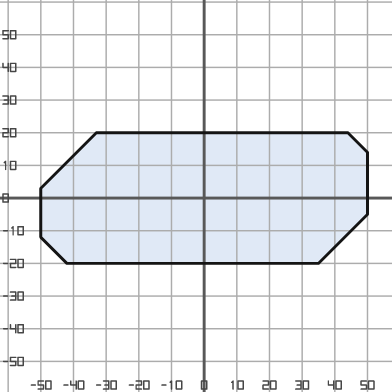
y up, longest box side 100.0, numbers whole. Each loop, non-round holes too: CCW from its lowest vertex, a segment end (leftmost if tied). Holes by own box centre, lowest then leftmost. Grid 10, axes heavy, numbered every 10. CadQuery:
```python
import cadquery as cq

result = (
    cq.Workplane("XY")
    .moveTo(-42.0, -20.0)
    .lineTo(35.0, -20.0)
    .lineTo(50.0, -5.0)
    .lineTo(50.0, 14.0)
    .lineTo(44.0, 20.0)
    .lineTo(-33.0, 20.0)
    .lineTo(-50.0, 3.0)
    .lineTo(-50.0, -12.0)
    .close()
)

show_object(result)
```